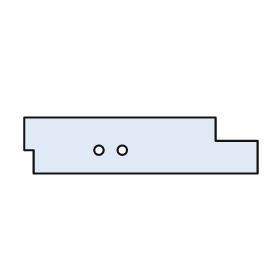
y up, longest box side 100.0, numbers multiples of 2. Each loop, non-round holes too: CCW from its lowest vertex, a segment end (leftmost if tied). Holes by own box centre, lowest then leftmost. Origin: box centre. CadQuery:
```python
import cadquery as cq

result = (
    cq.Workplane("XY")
    .moveTo(-46.0, -12.0)
    .lineTo(50.0, -12.0)
    .lineTo(50.0, 2.0)
    .lineTo(32.0, 2.0)
    .lineTo(32.0, 12.0)
    .lineTo(-50.0, 12.0)
    .lineTo(-50.0, -2.0)
    .lineTo(-46.0, -2.0)
    .close()
    .moveTo(-18.0, -2.0)
    .circle(2.0)
    .moveTo(-8.0, -2.0)
    .circle(2.0)
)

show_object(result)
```